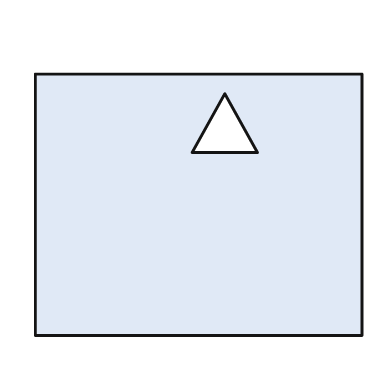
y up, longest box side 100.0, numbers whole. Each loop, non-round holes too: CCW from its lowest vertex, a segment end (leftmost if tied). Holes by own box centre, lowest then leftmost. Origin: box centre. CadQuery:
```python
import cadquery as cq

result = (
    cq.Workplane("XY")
    .moveTo(-50.0, -40.0)
    .lineTo(50.0, -40.0)
    .lineTo(50.0, 40.0)
    .lineTo(-50.0, 40.0)
    .close()
    .moveTo(-2.0, 16.0)
    .lineTo(18.0, 16.0)
    .lineTo(8.0, 34.0)
    .close()
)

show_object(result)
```